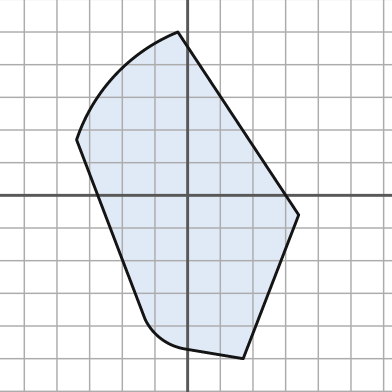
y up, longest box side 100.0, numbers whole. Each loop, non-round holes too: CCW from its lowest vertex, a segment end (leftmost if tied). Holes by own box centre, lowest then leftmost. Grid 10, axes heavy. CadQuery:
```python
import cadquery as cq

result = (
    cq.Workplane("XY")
    .moveTo(17.0, -50.0)
    .lineTo(34.0, -6.0)
    .lineTo(-3.0, 50.0)
    .threePointArc((-22.0, 37.0), (-34.0, 17.0))
    .lineTo(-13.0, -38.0)
    .threePointArc((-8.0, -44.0), (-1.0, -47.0))
    .close()
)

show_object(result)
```